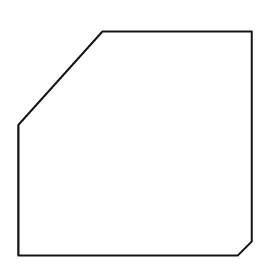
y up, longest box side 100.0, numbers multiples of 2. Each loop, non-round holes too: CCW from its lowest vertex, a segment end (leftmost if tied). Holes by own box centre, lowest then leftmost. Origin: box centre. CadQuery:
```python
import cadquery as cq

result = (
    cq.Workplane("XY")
    .moveTo(-50.0, -48.0)
    .lineTo(44.0, -48.0)
    .lineTo(50.0, -42.0)
    .lineTo(50.0, 48.0)
    .lineTo(-14.0, 48.0)
    .lineTo(-50.0, 8.0)
    .close()
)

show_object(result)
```